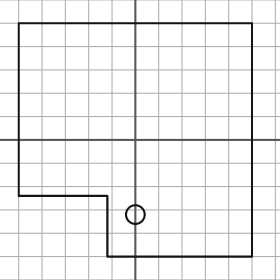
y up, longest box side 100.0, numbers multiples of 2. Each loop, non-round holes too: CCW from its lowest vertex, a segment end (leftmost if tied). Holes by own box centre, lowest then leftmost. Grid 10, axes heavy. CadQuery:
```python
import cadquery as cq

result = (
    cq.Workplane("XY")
    .moveTo(-12.0, -50.0)
    .lineTo(50.0, -50.0)
    .lineTo(50.0, 50.0)
    .lineTo(-50.0, 50.0)
    .lineTo(-50.0, -24.0)
    .lineTo(-12.0, -24.0)
    .close()
    .moveTo(0.0, -32.0)
    .circle(4.0)
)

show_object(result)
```